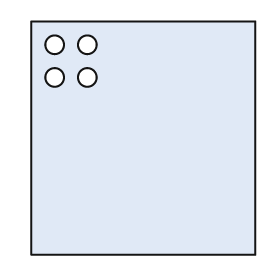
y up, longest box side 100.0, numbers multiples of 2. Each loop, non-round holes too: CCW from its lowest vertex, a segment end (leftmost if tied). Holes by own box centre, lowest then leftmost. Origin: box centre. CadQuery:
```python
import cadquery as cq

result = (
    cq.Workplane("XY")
    .moveTo(-48.0, -50.0)
    .lineTo(48.0, -50.0)
    .lineTo(48.0, 50.0)
    .lineTo(-48.0, 50.0)
    .close()
    .moveTo(-38.0, 26.0)
    .circle(4.0)
    .moveTo(-24.0, 26.0)
    .circle(4.0)
    .moveTo(-38.0, 40.0)
    .circle(4.0)
    .moveTo(-24.0, 40.0)
    .circle(4.0)
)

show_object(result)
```